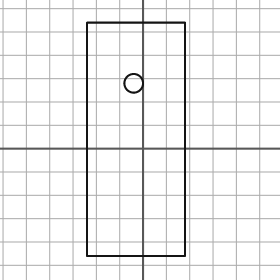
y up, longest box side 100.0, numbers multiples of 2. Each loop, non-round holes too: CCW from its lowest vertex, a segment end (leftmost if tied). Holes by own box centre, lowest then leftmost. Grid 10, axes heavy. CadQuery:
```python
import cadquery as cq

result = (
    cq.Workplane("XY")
    .moveTo(-24.0, -46.0)
    .lineTo(18.0, -46.0)
    .lineTo(18.0, 54.0)
    .lineTo(-24.0, 54.0)
    .close()
    .moveTo(-4.0, 28.0)
    .circle(4.0)
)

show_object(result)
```